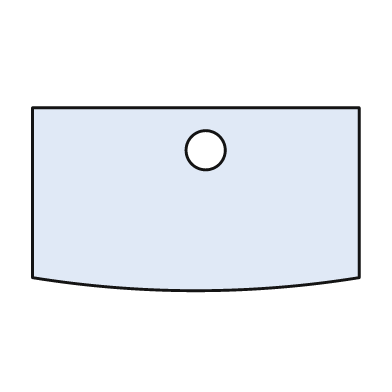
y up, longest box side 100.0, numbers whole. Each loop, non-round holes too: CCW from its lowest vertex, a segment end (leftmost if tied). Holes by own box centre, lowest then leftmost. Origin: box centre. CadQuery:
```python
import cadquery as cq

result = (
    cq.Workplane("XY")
    .moveTo(-50.0, -24.0)
    .threePointArc((0.0, -28.0), (50.0, -24.0))
    .lineTo(50.0, 28.0)
    .lineTo(-50.0, 28.0)
    .close()
    .moveTo(3.0, 15.0)
    .circle(6.0)
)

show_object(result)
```